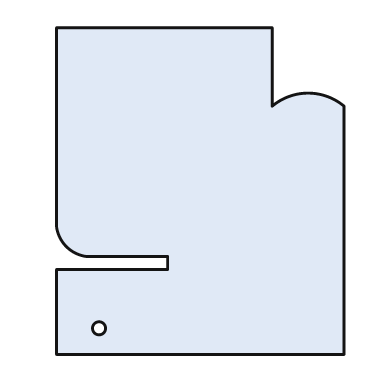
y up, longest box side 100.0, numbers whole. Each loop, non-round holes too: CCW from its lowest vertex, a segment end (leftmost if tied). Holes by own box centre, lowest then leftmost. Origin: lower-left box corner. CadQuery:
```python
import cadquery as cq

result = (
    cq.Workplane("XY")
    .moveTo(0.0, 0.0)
    .lineTo(88.0, 0.0)
    .lineTo(88.0, 76.0)
    .threePointArc((77.0, 80.0), (66.0, 76.0))
    .lineTo(66.0, 100.0)
    .lineTo(0.0, 100.0)
    .lineTo(0.0, 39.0)
    .threePointArc((3.0, 33.0), (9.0, 30.0))
    .lineTo(34.0, 30.0)
    .lineTo(34.0, 26.0)
    .lineTo(0.0, 26.0)
    .close()
    .moveTo(13.0, 8.0)
    .circle(2.0)
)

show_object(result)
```